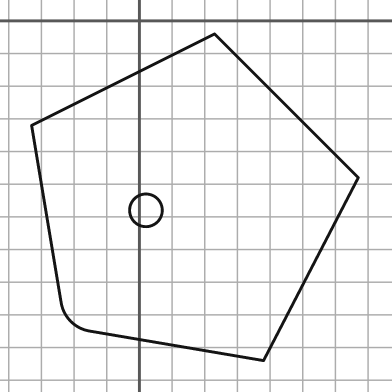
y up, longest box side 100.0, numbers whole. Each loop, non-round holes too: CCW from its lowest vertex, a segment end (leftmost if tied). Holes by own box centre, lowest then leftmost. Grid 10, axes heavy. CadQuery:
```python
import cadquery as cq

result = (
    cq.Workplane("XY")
    .moveTo(38.0, -104.0)
    .lineTo(67.0, -48.0)
    .lineTo(23.0, -4.0)
    .lineTo(-33.0, -32.0)
    .lineTo(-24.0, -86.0)
    .threePointArc((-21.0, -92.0), (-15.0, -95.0))
    .close()
    .moveTo(2.0, -58.0)
    .circle(5.0)
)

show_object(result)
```